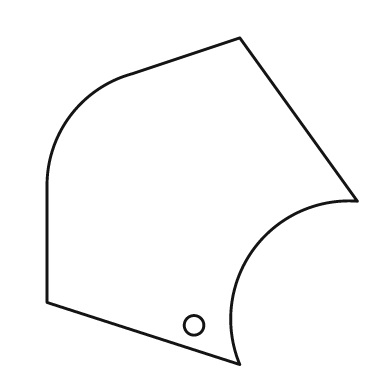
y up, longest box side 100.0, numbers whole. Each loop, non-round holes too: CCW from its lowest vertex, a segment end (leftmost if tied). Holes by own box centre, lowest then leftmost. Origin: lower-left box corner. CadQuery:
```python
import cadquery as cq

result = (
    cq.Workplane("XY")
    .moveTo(59.0, 0.0)
    .threePointArc((63.0, 35.0), (95.0, 50.0))
    .lineTo(59.0, 100.0)
    .lineTo(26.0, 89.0)
    .threePointArc((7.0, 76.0), (0.0, 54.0))
    .lineTo(0.0, 19.0)
    .close()
    .moveTo(45.0, 12.0)
    .circle(3.0)
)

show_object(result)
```